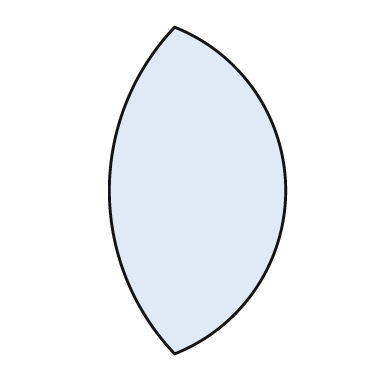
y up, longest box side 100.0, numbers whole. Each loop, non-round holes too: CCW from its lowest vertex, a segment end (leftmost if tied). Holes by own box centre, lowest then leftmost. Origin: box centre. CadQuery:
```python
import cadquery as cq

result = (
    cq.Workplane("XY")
    .moveTo(-7.0, -50.0)
    .threePointArc((27.0, 0.0), (-7.0, 50.0))
    .threePointArc((-27.0, 0.0), (-7.0, -50.0))
    .close()
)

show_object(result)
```